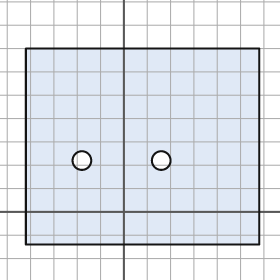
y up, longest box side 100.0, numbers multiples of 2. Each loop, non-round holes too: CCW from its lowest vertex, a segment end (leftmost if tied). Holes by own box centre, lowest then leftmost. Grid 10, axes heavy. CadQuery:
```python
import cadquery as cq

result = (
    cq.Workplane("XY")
    .moveTo(-42.0, -14.0)
    .lineTo(58.0, -14.0)
    .lineTo(58.0, 70.0)
    .lineTo(-42.0, 70.0)
    .close()
    .moveTo(-18.0, 22.0)
    .circle(4.0)
    .moveTo(16.0, 22.0)
    .circle(4.0)
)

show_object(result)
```